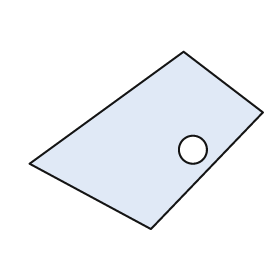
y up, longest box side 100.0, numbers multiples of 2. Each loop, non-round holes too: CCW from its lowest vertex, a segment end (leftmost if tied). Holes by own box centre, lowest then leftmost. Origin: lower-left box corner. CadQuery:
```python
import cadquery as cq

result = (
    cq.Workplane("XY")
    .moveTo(52.0, 0.0)
    .lineTo(100.0, 50.0)
    .lineTo(66.0, 76.0)
    .lineTo(0.0, 28.0)
    .close()
    .moveTo(70.0, 34.0)
    .circle(6.0)
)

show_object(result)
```